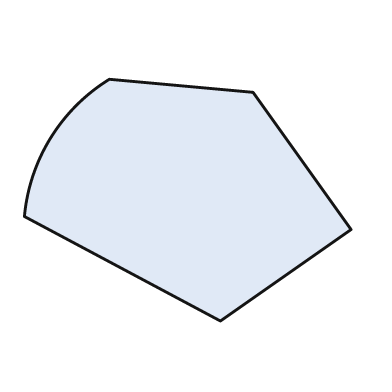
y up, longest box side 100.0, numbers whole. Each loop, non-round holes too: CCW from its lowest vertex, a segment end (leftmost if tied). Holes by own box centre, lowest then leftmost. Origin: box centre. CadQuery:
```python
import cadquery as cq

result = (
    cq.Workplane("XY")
    .moveTo(10.0, -37.0)
    .lineTo(50.0, -9.0)
    .lineTo(20.0, 33.0)
    .lineTo(-24.0, 37.0)
    .threePointArc((-42.0, 19.0), (-50.0, -5.0))
    .close()
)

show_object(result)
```